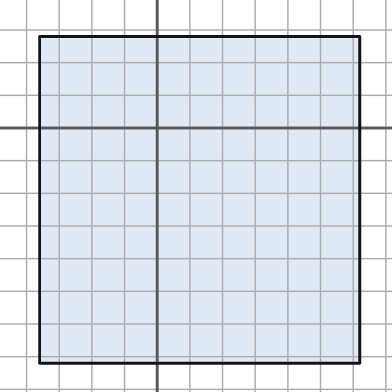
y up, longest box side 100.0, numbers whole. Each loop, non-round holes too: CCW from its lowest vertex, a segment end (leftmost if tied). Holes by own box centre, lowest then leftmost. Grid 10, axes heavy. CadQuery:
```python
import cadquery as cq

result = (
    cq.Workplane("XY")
    .moveTo(-36.0, -72.0)
    .lineTo(62.0, -72.0)
    .lineTo(62.0, 28.0)
    .lineTo(-36.0, 28.0)
    .close()
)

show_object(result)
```